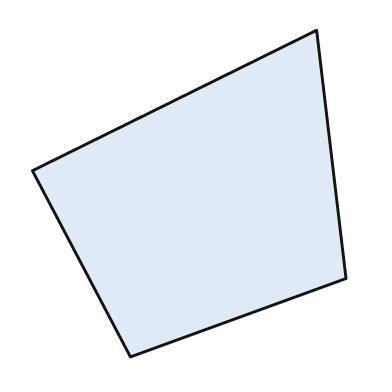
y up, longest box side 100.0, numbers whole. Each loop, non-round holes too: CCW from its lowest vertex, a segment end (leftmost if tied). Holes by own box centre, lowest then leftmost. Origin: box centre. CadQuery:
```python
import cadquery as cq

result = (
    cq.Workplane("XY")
    .moveTo(-18.0, -50.0)
    .lineTo(48.0, -26.0)
    .lineTo(39.0, 50.0)
    .lineTo(-48.0, 7.0)
    .close()
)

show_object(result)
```